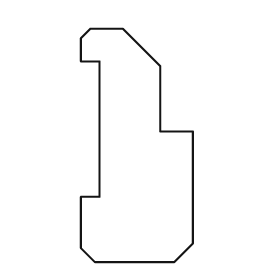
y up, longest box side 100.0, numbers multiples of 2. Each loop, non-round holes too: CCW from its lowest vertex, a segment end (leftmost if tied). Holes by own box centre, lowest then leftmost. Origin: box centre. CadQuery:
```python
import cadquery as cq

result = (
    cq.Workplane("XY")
    .moveTo(-18.0, -50.0)
    .lineTo(16.0, -50.0)
    .lineTo(24.0, -42.0)
    .lineTo(24.0, 6.0)
    .lineTo(10.0, 6.0)
    .lineTo(10.0, 34.0)
    .lineTo(-6.0, 50.0)
    .lineTo(-20.0, 50.0)
    .lineTo(-24.0, 46.0)
    .lineTo(-24.0, 36.0)
    .lineTo(-16.0, 36.0)
    .lineTo(-16.0, -22.0)
    .lineTo(-24.0, -22.0)
    .lineTo(-24.0, -44.0)
    .close()
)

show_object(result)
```